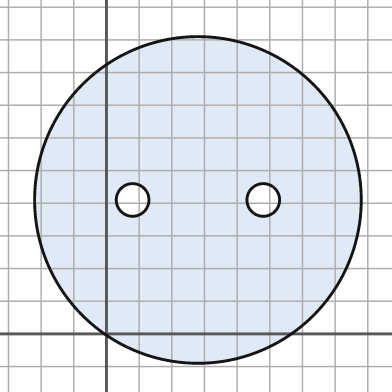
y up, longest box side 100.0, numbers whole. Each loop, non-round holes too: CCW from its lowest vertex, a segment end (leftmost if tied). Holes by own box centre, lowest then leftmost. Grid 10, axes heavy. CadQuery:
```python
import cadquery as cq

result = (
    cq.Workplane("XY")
    .moveTo(28.0, 41.0)
    .circle(50.0)
    .moveTo(8.0, 41.0)
    .circle(5.0)
    .moveTo(48.0, 41.0)
    .circle(5.0)
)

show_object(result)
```